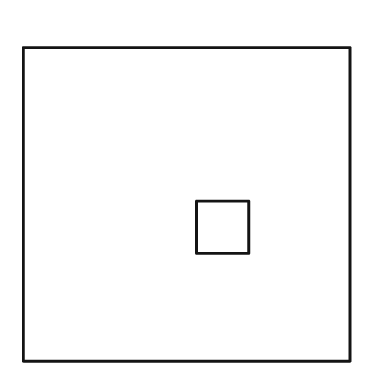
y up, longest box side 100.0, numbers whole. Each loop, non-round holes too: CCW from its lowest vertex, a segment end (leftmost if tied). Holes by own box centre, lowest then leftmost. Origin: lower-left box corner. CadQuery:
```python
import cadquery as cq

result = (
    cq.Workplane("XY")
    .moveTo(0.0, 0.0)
    .lineTo(100.0, 0.0)
    .lineTo(100.0, 96.0)
    .lineTo(0.0, 96.0)
    .close()
    .moveTo(53.0, 33.0)
    .lineTo(69.0, 33.0)
    .lineTo(69.0, 49.0)
    .lineTo(53.0, 49.0)
    .close()
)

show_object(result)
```